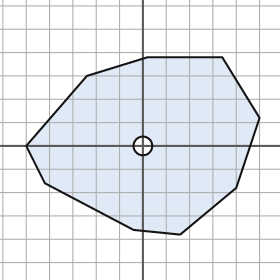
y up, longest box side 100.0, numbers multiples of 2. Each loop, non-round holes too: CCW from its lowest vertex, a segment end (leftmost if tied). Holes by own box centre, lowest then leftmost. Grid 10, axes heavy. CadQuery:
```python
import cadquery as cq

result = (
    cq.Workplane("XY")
    .moveTo(16.0, -38.0)
    .lineTo(40.0, -18.0)
    .lineTo(50.0, 12.0)
    .lineTo(34.0, 38.0)
    .lineTo(2.0, 38.0)
    .lineTo(-24.0, 30.0)
    .lineTo(-50.0, 0.0)
    .lineTo(-42.0, -16.0)
    .lineTo(-4.0, -36.0)
    .close()
    .moveTo(0.0, 0.0)
    .circle(4.0)
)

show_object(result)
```